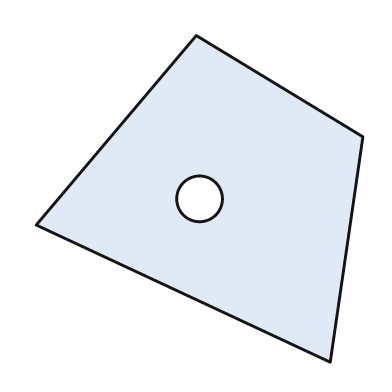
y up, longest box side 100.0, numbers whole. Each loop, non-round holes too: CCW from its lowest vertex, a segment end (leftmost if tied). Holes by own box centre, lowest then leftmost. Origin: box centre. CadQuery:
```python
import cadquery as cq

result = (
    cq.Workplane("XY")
    .moveTo(40.0, -50.0)
    .lineTo(50.0, 19.0)
    .lineTo(-1.0, 50.0)
    .lineTo(-50.0, -8.0)
    .close()
    .moveTo(0.0, 0.0)
    .circle(7.0)
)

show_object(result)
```